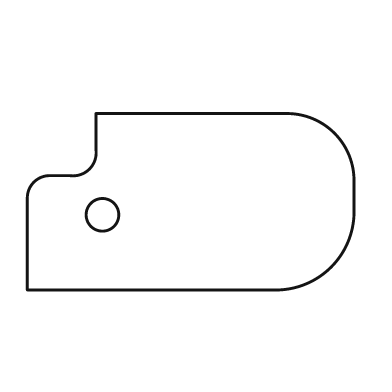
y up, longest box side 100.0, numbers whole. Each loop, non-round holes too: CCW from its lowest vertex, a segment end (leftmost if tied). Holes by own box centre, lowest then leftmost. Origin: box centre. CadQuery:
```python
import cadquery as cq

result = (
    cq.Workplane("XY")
    .moveTo(-50.0, -27.0)
    .lineTo(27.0, -27.0)
    .threePointArc((43.0, -20.0), (50.0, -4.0))
    .lineTo(50.0, 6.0)
    .threePointArc((44.0, 21.0), (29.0, 27.0))
    .lineTo(-29.0, 27.0)
    .lineTo(-29.0, 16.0)
    .threePointArc((-31.0, 10.0), (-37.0, 8.0))
    .lineTo(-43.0, 8.0)
    .threePointArc((-48.0, 6.0), (-50.0, 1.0))
    .close()
    .moveTo(-27.0, -4.0)
    .circle(5.0)
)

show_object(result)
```